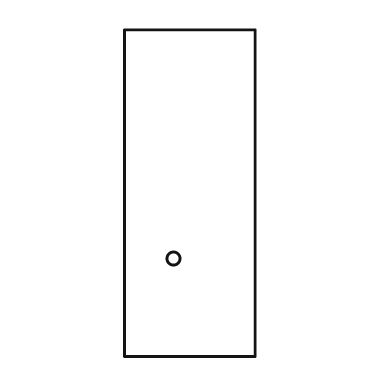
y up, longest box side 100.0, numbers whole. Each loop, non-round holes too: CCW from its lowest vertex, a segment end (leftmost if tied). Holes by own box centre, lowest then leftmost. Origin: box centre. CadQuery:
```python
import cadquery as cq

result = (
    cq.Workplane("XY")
    .moveTo(-20.0, -50.0)
    .lineTo(20.0, -50.0)
    .lineTo(20.0, 50.0)
    .lineTo(-20.0, 50.0)
    .close()
    .moveTo(-5.0, -20.0)
    .circle(2.0)
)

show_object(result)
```